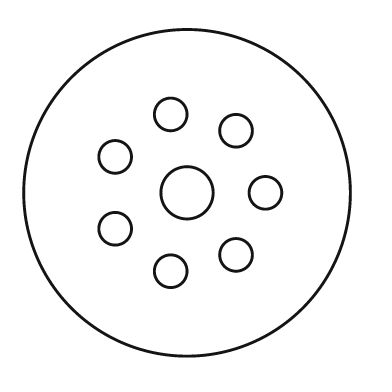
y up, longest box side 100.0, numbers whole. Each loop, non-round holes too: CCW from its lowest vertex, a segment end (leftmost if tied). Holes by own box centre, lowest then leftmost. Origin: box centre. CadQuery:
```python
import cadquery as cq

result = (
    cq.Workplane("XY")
    .moveTo(0.0, 0.0)
    .circle(50.0)
    .moveTo(-5.0, -24.0)
    .circle(5.0)
    .moveTo(15.0, -19.0)
    .circle(5.0)
    .moveTo(-22.0, -11.0)
    .circle(5.0)
    .moveTo(0.0, 0.0)
    .circle(8.0)
    .moveTo(24.0, 0.0)
    .circle(5.0)
    .moveTo(-22.0, 11.0)
    .circle(5.0)
    .moveTo(15.0, 19.0)
    .circle(5.0)
    .moveTo(-5.0, 24.0)
    .circle(5.0)
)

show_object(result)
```